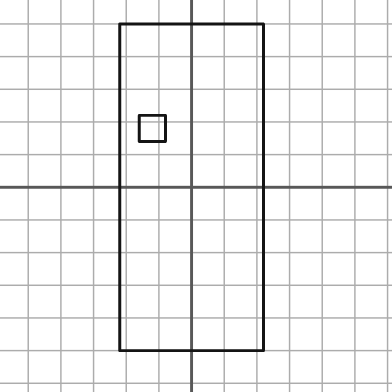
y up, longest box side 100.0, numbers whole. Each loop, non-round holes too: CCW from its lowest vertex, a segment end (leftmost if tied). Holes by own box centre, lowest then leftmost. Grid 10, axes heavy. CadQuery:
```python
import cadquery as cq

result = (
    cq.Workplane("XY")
    .moveTo(-22.0, -50.0)
    .lineTo(22.0, -50.0)
    .lineTo(22.0, 50.0)
    .lineTo(-22.0, 50.0)
    .close()
    .moveTo(-16.0, 14.0)
    .lineTo(-8.0, 14.0)
    .lineTo(-8.0, 22.0)
    .lineTo(-16.0, 22.0)
    .close()
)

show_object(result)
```